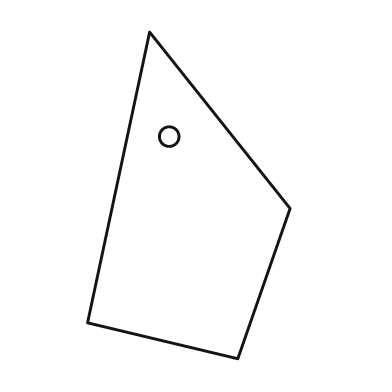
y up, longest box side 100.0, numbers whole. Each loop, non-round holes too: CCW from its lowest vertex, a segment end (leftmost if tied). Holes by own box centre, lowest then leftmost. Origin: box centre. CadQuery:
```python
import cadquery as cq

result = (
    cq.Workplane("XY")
    .moveTo(15.0, -50.0)
    .lineTo(31.0, -4.0)
    .lineTo(-12.0, 50.0)
    .lineTo(-31.0, -39.0)
    .close()
    .moveTo(-6.0, 18.0)
    .circle(3.0)
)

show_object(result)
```